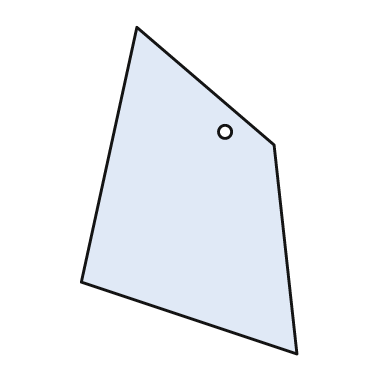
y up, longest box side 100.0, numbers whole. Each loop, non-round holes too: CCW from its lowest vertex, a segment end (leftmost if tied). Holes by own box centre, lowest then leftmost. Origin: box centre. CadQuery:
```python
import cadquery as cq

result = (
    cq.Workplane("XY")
    .moveTo(33.0, -50.0)
    .lineTo(26.0, 14.0)
    .lineTo(-16.0, 50.0)
    .lineTo(-33.0, -28.0)
    .close()
    .moveTo(11.0, 18.0)
    .circle(2.0)
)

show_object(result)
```